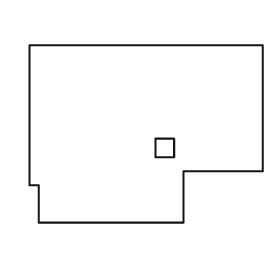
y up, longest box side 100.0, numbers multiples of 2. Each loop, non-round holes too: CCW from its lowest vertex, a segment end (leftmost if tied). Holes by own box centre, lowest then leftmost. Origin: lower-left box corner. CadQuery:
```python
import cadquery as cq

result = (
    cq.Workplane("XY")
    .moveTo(4.0, 0.0)
    .lineTo(66.0, 0.0)
    .lineTo(66.0, 22.0)
    .lineTo(100.0, 22.0)
    .lineTo(100.0, 76.0)
    .lineTo(0.0, 76.0)
    .lineTo(0.0, 16.0)
    .lineTo(4.0, 16.0)
    .close()
    .moveTo(54.0, 28.0)
    .lineTo(62.0, 28.0)
    .lineTo(62.0, 36.0)
    .lineTo(54.0, 36.0)
    .close()
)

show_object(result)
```